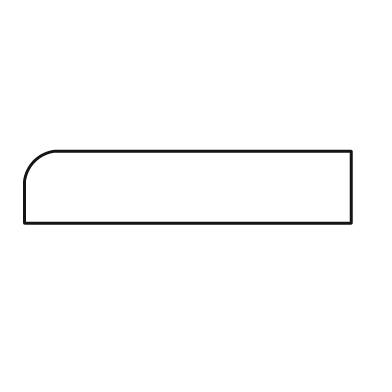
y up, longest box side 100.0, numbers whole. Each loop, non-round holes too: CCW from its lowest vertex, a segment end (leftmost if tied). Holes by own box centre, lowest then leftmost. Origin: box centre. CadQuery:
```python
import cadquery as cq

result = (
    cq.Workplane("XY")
    .moveTo(-50.0, -11.0)
    .lineTo(50.0, -11.0)
    .lineTo(50.0, 11.0)
    .lineTo(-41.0, 11.0)
    .threePointArc((-47.0, 8.0), (-50.0, 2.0))
    .close()
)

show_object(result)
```